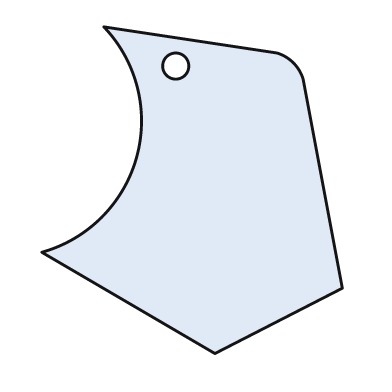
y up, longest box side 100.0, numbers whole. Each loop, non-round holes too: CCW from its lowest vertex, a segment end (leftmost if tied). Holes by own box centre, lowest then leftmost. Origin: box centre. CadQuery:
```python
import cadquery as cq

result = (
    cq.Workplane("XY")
    .moveTo(7.0, -50.0)
    .lineTo(46.0, -30.0)
    .lineTo(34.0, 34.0)
    .threePointArc((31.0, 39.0), (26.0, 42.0))
    .lineTo(-27.0, 50.0)
    .threePointArc((-17.0, 10.0), (-46.0, -19.0))
    .close()
    .moveTo(-5.0, 38.0)
    .circle(4.0)
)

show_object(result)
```